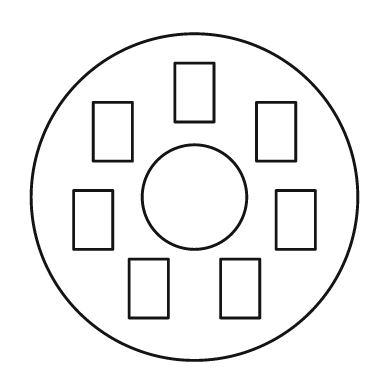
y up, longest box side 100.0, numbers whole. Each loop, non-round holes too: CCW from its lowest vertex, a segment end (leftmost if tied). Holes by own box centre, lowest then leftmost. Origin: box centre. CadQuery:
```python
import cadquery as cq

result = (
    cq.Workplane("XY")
    .moveTo(0.0, 0.0)
    .circle(50.0)
    .moveTo(-20.0, -37.0)
    .lineTo(-8.0, -37.0)
    .lineTo(-8.0, -19.0)
    .lineTo(-20.0, -19.0)
    .close()
    .moveTo(8.0, -37.0)
    .lineTo(20.0, -37.0)
    .lineTo(20.0, -19.0)
    .lineTo(8.0, -19.0)
    .close()
    .moveTo(-37.0, -16.0)
    .lineTo(-25.0, -16.0)
    .lineTo(-25.0, 2.0)
    .lineTo(-37.0, 2.0)
    .close()
    .moveTo(25.0, -16.0)
    .lineTo(37.0, -16.0)
    .lineTo(37.0, 2.0)
    .lineTo(25.0, 2.0)
    .close()
    .moveTo(0.0, 0.0)
    .circle(16.0)
    .moveTo(-31.0, 11.0)
    .lineTo(-19.0, 11.0)
    .lineTo(-19.0, 29.0)
    .lineTo(-31.0, 29.0)
    .close()
    .moveTo(19.0, 11.0)
    .lineTo(31.0, 11.0)
    .lineTo(31.0, 29.0)
    .lineTo(19.0, 29.0)
    .close()
    .moveTo(-6.0, 23.0)
    .lineTo(6.0, 23.0)
    .lineTo(6.0, 41.0)
    .lineTo(-6.0, 41.0)
    .close()
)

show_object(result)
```